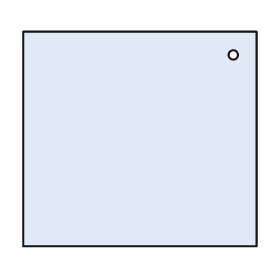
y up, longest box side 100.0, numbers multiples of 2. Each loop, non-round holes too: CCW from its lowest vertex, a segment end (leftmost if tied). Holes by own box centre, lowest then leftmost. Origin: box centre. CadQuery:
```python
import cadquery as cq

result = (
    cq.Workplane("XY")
    .moveTo(-50.0, -46.0)
    .lineTo(50.0, -46.0)
    .lineTo(50.0, 46.0)
    .lineTo(-50.0, 46.0)
    .close()
    .moveTo(40.0, 36.0)
    .circle(2.0)
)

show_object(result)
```